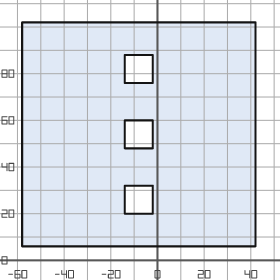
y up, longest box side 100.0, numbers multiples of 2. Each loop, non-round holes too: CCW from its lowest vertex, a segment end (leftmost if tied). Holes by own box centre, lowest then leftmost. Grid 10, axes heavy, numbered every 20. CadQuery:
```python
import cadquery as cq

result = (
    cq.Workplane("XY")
    .moveTo(-58.0, 6.0)
    .lineTo(42.0, 6.0)
    .lineTo(42.0, 102.0)
    .lineTo(-58.0, 102.0)
    .close()
    .moveTo(-14.0, 20.0)
    .lineTo(-2.0, 20.0)
    .lineTo(-2.0, 32.0)
    .lineTo(-14.0, 32.0)
    .close()
    .moveTo(-14.0, 48.0)
    .lineTo(-2.0, 48.0)
    .lineTo(-2.0, 60.0)
    .lineTo(-14.0, 60.0)
    .close()
    .moveTo(-14.0, 76.0)
    .lineTo(-2.0, 76.0)
    .lineTo(-2.0, 88.0)
    .lineTo(-14.0, 88.0)
    .close()
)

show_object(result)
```